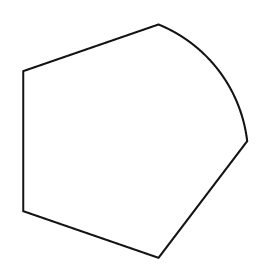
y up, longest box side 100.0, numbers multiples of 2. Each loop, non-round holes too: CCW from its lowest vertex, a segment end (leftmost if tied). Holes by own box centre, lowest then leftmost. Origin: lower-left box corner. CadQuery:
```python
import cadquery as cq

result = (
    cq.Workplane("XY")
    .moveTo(58.0, 0.0)
    .lineTo(96.0, 50.0)
    .threePointArc((84.0, 80.0), (58.0, 100.0))
    .lineTo(0.0, 80.0)
    .lineTo(0.0, 20.0)
    .close()
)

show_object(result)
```